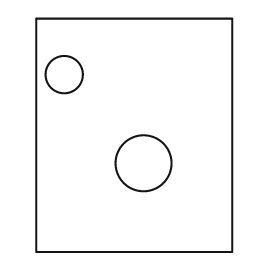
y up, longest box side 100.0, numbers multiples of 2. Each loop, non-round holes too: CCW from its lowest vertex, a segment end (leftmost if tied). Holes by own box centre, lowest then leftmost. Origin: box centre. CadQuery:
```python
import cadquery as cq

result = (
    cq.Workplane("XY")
    .moveTo(-42.0, -50.0)
    .lineTo(42.0, -50.0)
    .lineTo(42.0, 50.0)
    .lineTo(-42.0, 50.0)
    .close()
    .moveTo(4.0, -12.0)
    .circle(12.0)
    .moveTo(-30.0, 26.0)
    .circle(8.0)
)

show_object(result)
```